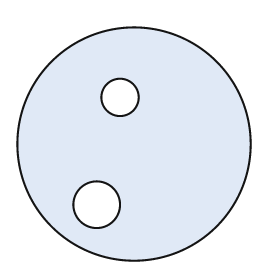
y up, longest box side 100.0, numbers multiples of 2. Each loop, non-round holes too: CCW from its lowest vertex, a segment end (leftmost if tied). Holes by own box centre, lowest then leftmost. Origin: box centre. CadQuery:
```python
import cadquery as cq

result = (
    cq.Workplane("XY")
    .moveTo(0.0, 0.0)
    .circle(50.0)
    .moveTo(-16.0, -26.0)
    .circle(10.0)
    .moveTo(-6.0, 20.0)
    .circle(8.0)
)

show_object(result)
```